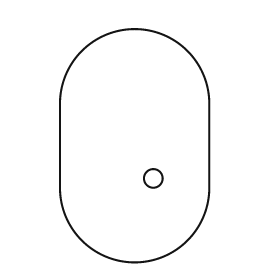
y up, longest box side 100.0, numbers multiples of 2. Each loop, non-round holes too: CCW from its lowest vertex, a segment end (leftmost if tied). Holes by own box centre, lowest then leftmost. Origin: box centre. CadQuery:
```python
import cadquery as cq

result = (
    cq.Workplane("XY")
    .moveTo(-32.0, -18.0)
    .threePointArc((0.0, -50.0), (32.0, -18.0))
    .lineTo(32.0, 18.0)
    .threePointArc((0.0, 50.0), (-32.0, 18.0))
    .close()
    .moveTo(8.0, -14.0)
    .circle(4.0)
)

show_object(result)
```